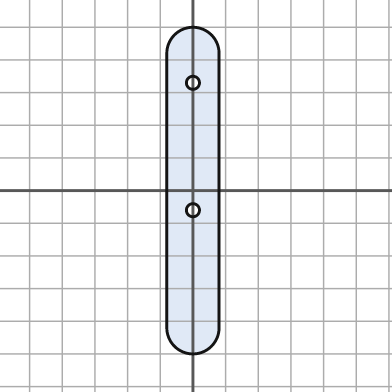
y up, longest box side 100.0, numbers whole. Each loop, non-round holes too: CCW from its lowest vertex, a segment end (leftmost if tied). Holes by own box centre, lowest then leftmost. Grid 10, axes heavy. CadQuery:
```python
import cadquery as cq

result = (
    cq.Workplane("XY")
    .moveTo(-8.0, -42.0)
    .threePointArc((0.0, -50.0), (8.0, -42.0))
    .lineTo(8.0, 42.0)
    .threePointArc((0.0, 50.0), (-8.0, 42.0))
    .close()
    .moveTo(0.0, -6.0)
    .circle(2.0)
    .moveTo(0.0, 33.0)
    .circle(2.0)
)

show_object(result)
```